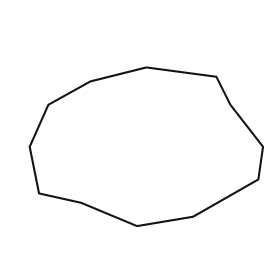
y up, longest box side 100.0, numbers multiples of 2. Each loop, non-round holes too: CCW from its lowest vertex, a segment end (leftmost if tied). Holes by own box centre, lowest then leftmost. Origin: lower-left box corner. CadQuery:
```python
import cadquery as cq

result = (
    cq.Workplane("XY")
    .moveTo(46.0, 0.0)
    .lineTo(70.0, 4.0)
    .lineTo(98.0, 20.0)
    .lineTo(100.0, 34.0)
    .lineTo(86.0, 52.0)
    .lineTo(80.0, 64.0)
    .lineTo(50.0, 68.0)
    .lineTo(26.0, 62.0)
    .lineTo(8.0, 52.0)
    .lineTo(0.0, 34.0)
    .lineTo(4.0, 14.0)
    .lineTo(22.0, 10.0)
    .close()
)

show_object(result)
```